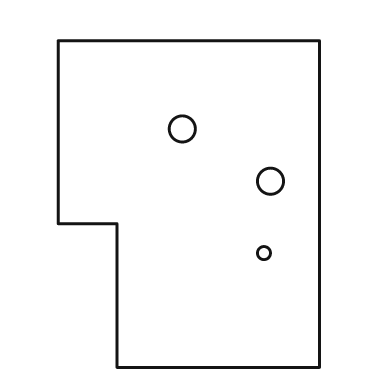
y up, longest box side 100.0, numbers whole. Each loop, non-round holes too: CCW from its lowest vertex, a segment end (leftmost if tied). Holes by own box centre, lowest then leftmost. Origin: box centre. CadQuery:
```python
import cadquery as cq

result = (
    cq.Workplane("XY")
    .moveTo(-22.0, -50.0)
    .lineTo(40.0, -50.0)
    .lineTo(40.0, 50.0)
    .lineTo(-40.0, 50.0)
    .lineTo(-40.0, -6.0)
    .lineTo(-22.0, -6.0)
    .close()
    .moveTo(23.0, -15.0)
    .circle(2.0)
    .moveTo(25.0, 7.0)
    .circle(4.0)
    .moveTo(-2.0, 23.0)
    .circle(4.0)
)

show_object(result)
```